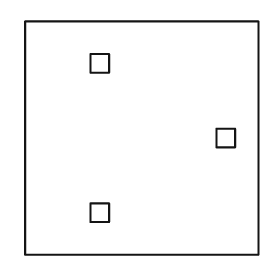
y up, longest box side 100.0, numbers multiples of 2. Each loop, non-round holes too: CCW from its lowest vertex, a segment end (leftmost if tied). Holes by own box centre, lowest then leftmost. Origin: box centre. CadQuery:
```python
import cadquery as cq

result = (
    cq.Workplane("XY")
    .moveTo(-50.0, -50.0)
    .lineTo(50.0, -50.0)
    .lineTo(50.0, 50.0)
    .lineTo(-50.0, 50.0)
    .close()
    .moveTo(-22.0, -36.0)
    .lineTo(-14.0, -36.0)
    .lineTo(-14.0, -28.0)
    .lineTo(-22.0, -28.0)
    .close()
    .moveTo(32.0, -4.0)
    .lineTo(40.0, -4.0)
    .lineTo(40.0, 4.0)
    .lineTo(32.0, 4.0)
    .close()
    .moveTo(-22.0, 28.0)
    .lineTo(-14.0, 28.0)
    .lineTo(-14.0, 36.0)
    .lineTo(-22.0, 36.0)
    .close()
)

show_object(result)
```